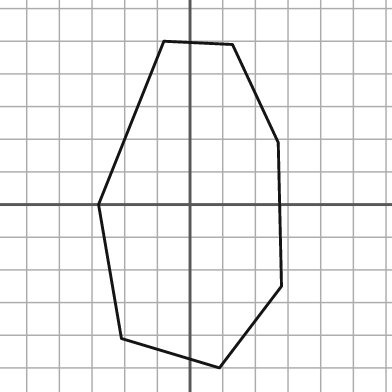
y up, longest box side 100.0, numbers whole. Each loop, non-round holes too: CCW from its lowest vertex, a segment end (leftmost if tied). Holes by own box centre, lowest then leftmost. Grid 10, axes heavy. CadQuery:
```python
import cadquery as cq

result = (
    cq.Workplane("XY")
    .moveTo(9.0, -50.0)
    .lineTo(28.0, -25.0)
    .lineTo(27.0, 19.0)
    .lineTo(13.0, 49.0)
    .lineTo(-8.0, 50.0)
    .lineTo(-28.0, 0.0)
    .lineTo(-21.0, -41.0)
    .close()
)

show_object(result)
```